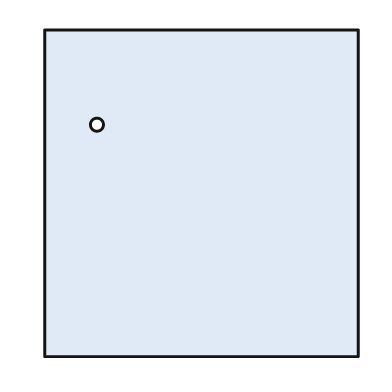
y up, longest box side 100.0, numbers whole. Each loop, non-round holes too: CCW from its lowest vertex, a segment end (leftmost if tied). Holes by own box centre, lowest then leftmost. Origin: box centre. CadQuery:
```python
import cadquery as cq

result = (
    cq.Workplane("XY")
    .moveTo(-48.0, -50.0)
    .lineTo(48.0, -50.0)
    .lineTo(48.0, 50.0)
    .lineTo(-48.0, 50.0)
    .close()
    .moveTo(-32.0, 21.0)
    .circle(2.0)
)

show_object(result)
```